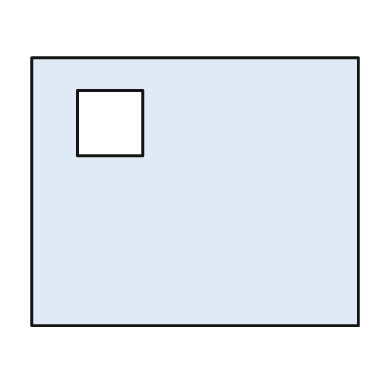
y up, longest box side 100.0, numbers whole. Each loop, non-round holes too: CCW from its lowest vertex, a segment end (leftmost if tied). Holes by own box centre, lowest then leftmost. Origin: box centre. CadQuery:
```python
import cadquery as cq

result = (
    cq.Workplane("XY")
    .moveTo(-50.0, -41.0)
    .lineTo(50.0, -41.0)
    .lineTo(50.0, 41.0)
    .lineTo(-50.0, 41.0)
    .close()
    .moveTo(-36.0, 11.0)
    .lineTo(-16.0, 11.0)
    .lineTo(-16.0, 31.0)
    .lineTo(-36.0, 31.0)
    .close()
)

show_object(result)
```